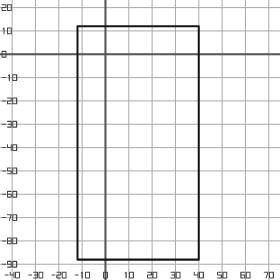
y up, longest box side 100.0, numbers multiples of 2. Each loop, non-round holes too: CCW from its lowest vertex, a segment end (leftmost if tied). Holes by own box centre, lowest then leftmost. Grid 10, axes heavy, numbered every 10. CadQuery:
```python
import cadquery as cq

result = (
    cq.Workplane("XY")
    .moveTo(-12.0, -88.0)
    .lineTo(40.0, -88.0)
    .lineTo(40.0, 12.0)
    .lineTo(-12.0, 12.0)
    .close()
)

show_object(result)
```